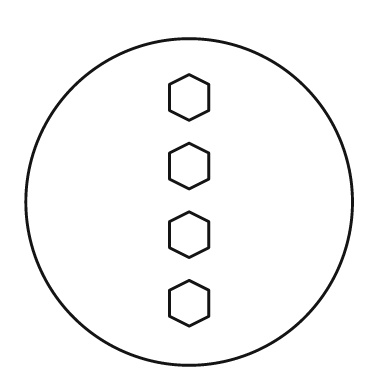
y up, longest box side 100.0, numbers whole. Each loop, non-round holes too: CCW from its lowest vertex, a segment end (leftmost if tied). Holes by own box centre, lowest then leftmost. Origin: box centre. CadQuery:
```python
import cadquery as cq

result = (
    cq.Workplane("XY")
    .moveTo(0.0, 0.0)
    .circle(50.0)
    .moveTo(0.0, -38.0)
    .lineTo(6.0, -35.0)
    .lineTo(6.0, -27.0)
    .lineTo(0.0, -24.0)
    .lineTo(-6.0, -27.0)
    .lineTo(-6.0, -35.0)
    .close()
    .moveTo(0.0, -17.0)
    .lineTo(6.0, -14.0)
    .lineTo(6.0, -6.0)
    .lineTo(0.0, -3.0)
    .lineTo(-6.0, -6.0)
    .lineTo(-6.0, -14.0)
    .close()
    .moveTo(0.0, 4.0)
    .lineTo(6.0, 7.0)
    .lineTo(6.0, 15.0)
    .lineTo(0.0, 18.0)
    .lineTo(-6.0, 15.0)
    .lineTo(-6.0, 7.0)
    .close()
    .moveTo(0.0, 25.0)
    .lineTo(6.0, 28.0)
    .lineTo(6.0, 36.0)
    .lineTo(0.0, 39.0)
    .lineTo(-6.0, 36.0)
    .lineTo(-6.0, 28.0)
    .close()
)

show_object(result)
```